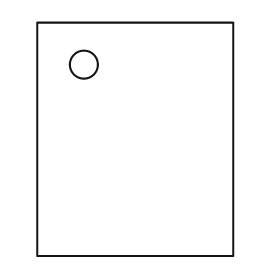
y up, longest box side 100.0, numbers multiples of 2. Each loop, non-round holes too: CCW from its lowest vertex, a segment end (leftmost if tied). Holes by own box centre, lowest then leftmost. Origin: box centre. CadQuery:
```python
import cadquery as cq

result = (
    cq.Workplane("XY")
    .moveTo(-42.0, -50.0)
    .lineTo(42.0, -50.0)
    .lineTo(42.0, 50.0)
    .lineTo(-42.0, 50.0)
    .close()
    .moveTo(-22.0, 32.0)
    .circle(6.0)
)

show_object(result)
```